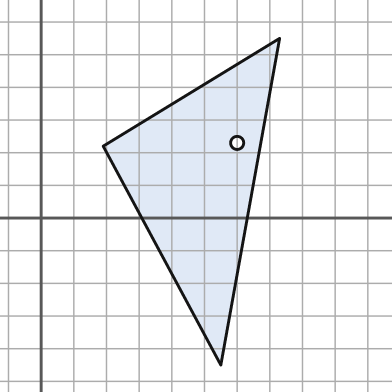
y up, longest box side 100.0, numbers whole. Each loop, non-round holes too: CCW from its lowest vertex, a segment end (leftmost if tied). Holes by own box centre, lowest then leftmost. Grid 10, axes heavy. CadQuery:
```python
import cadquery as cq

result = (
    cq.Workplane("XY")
    .moveTo(55.0, -45.0)
    .lineTo(73.0, 55.0)
    .lineTo(19.0, 22.0)
    .close()
    .moveTo(60.0, 23.0)
    .circle(2.0)
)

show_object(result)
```